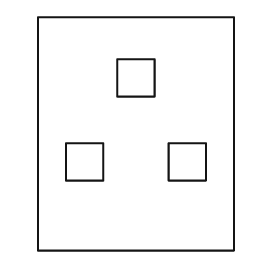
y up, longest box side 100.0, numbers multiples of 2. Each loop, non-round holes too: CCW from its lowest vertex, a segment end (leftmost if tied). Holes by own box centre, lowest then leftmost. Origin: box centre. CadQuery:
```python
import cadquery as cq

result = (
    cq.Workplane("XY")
    .moveTo(-42.0, -50.0)
    .lineTo(42.0, -50.0)
    .lineTo(42.0, 50.0)
    .lineTo(-42.0, 50.0)
    .close()
    .moveTo(-30.0, -20.0)
    .lineTo(-14.0, -20.0)
    .lineTo(-14.0, -4.0)
    .lineTo(-30.0, -4.0)
    .close()
    .moveTo(14.0, -20.0)
    .lineTo(30.0, -20.0)
    .lineTo(30.0, -4.0)
    .lineTo(14.0, -4.0)
    .close()
    .moveTo(-8.0, 16.0)
    .lineTo(8.0, 16.0)
    .lineTo(8.0, 32.0)
    .lineTo(-8.0, 32.0)
    .close()
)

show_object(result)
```